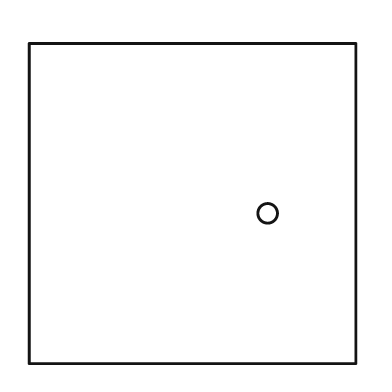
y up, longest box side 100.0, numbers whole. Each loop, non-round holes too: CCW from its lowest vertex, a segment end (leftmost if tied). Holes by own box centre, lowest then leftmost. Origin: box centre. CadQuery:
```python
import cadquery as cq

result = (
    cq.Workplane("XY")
    .moveTo(-50.0, -49.0)
    .lineTo(50.0, -49.0)
    .lineTo(50.0, 49.0)
    .lineTo(-50.0, 49.0)
    .close()
    .moveTo(23.0, -3.0)
    .circle(3.0)
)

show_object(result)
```